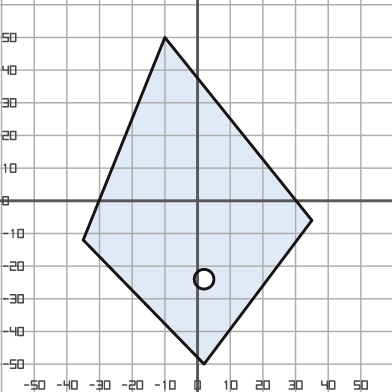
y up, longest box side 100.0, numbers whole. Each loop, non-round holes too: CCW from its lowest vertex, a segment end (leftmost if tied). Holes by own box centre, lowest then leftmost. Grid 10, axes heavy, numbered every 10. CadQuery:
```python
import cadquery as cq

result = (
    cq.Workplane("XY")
    .moveTo(2.0, -50.0)
    .lineTo(35.0, -6.0)
    .lineTo(-10.0, 50.0)
    .lineTo(-35.0, -12.0)
    .close()
    .moveTo(2.0, -24.0)
    .circle(3.0)
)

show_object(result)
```